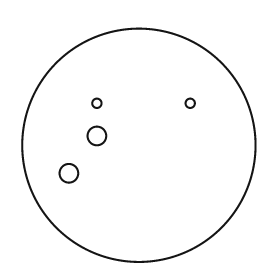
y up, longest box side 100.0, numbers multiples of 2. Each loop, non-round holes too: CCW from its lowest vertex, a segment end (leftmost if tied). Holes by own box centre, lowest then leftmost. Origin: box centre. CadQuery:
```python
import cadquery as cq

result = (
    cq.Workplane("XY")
    .moveTo(0.0, 0.0)
    .circle(50.0)
    .moveTo(-30.0, -12.0)
    .circle(4.0)
    .moveTo(-18.0, 4.0)
    .circle(4.0)
    .moveTo(-18.0, 18.0)
    .circle(2.0)
    .moveTo(22.0, 18.0)
    .circle(2.0)
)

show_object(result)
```